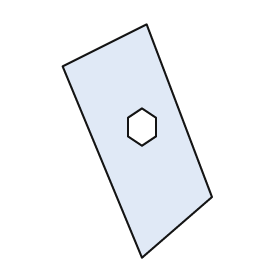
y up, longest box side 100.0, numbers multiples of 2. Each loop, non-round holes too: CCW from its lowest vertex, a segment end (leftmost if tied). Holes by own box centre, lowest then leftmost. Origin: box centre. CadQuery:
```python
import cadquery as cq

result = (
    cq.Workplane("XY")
    .moveTo(2.0, -50.0)
    .lineTo(32.0, -24.0)
    .lineTo(4.0, 50.0)
    .lineTo(-32.0, 32.0)
    .close()
    .moveTo(2.0, -2.0)
    .lineTo(8.0, 2.0)
    .lineTo(8.0, 10.0)
    .lineTo(2.0, 14.0)
    .lineTo(-4.0, 10.0)
    .lineTo(-4.0, 2.0)
    .close()
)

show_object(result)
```